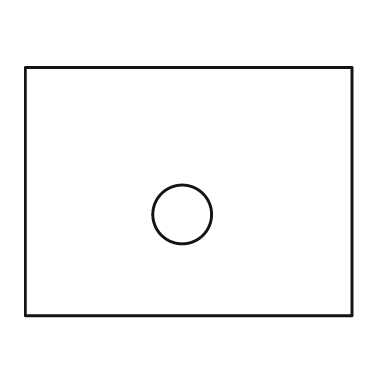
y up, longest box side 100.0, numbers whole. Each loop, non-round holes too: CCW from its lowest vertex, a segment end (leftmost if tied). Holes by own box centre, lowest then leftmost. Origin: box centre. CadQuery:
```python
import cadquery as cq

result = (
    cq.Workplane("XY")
    .moveTo(-50.0, -38.0)
    .lineTo(50.0, -38.0)
    .lineTo(50.0, 38.0)
    .lineTo(-50.0, 38.0)
    .close()
    .moveTo(-2.0, -7.0)
    .circle(9.0)
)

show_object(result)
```